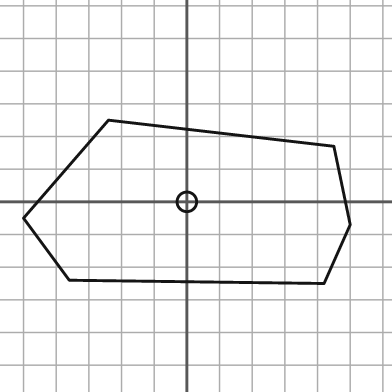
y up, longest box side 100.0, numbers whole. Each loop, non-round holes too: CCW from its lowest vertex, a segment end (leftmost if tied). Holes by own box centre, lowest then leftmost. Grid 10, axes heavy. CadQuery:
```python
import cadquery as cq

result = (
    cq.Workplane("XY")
    .moveTo(42.0, -25.0)
    .lineTo(50.0, -7.0)
    .lineTo(45.0, 17.0)
    .lineTo(-24.0, 25.0)
    .lineTo(-50.0, -5.0)
    .lineTo(-36.0, -24.0)
    .close()
    .moveTo(0.0, 0.0)
    .circle(3.0)
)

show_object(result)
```